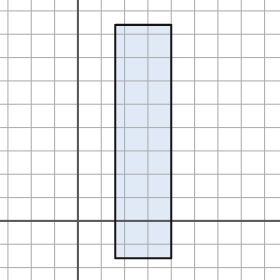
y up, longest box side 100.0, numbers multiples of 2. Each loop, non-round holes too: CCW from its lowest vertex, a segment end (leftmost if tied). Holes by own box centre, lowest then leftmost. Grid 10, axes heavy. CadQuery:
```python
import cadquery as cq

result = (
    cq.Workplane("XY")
    .moveTo(16.0, -16.0)
    .lineTo(40.0, -16.0)
    .lineTo(40.0, 84.0)
    .lineTo(16.0, 84.0)
    .close()
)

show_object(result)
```